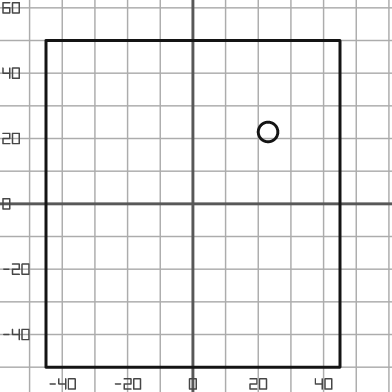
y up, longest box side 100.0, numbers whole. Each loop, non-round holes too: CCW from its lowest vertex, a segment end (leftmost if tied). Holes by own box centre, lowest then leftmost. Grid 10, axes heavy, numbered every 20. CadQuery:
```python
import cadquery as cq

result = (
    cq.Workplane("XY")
    .moveTo(-45.0, -50.0)
    .lineTo(45.0, -50.0)
    .lineTo(45.0, 50.0)
    .lineTo(-45.0, 50.0)
    .close()
    .moveTo(23.0, 22.0)
    .circle(3.0)
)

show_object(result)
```